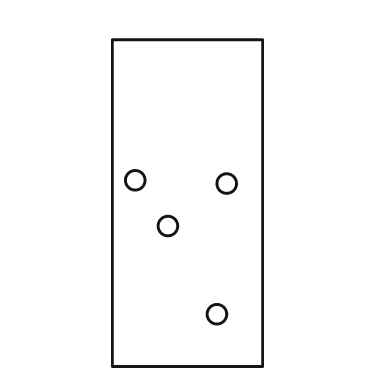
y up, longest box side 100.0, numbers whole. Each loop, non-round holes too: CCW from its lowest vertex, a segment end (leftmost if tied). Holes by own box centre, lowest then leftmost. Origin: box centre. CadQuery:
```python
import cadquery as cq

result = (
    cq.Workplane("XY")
    .moveTo(-23.0, -50.0)
    .lineTo(23.0, -50.0)
    .lineTo(23.0, 50.0)
    .lineTo(-23.0, 50.0)
    .close()
    .moveTo(9.0, -34.0)
    .circle(3.0)
    .moveTo(-6.0, -7.0)
    .circle(3.0)
    .moveTo(12.0, 6.0)
    .circle(3.0)
    .moveTo(-16.0, 7.0)
    .circle(3.0)
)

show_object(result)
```